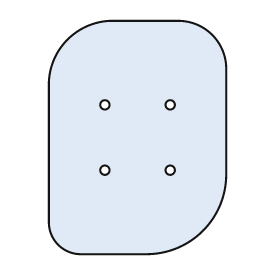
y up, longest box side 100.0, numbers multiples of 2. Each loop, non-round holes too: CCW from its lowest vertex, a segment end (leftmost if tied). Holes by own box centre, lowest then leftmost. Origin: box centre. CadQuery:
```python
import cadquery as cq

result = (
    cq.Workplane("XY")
    .moveTo(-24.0, -50.0)
    .lineTo(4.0, -50.0)
    .threePointArc((28.0, -40.0), (38.0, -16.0))
    .lineTo(38.0, 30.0)
    .threePointArc((32.0, 44.0), (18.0, 50.0))
    .lineTo(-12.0, 50.0)
    .threePointArc((-30.0, 42.0), (-38.0, 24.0))
    .lineTo(-38.0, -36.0)
    .threePointArc((-34.0, -46.0), (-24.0, -50.0))
    .close()
    .moveTo(-14.0, -14.0)
    .circle(2.0)
    .moveTo(14.0, -14.0)
    .circle(2.0)
    .moveTo(-14.0, 14.0)
    .circle(2.0)
    .moveTo(14.0, 14.0)
    .circle(2.0)
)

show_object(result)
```